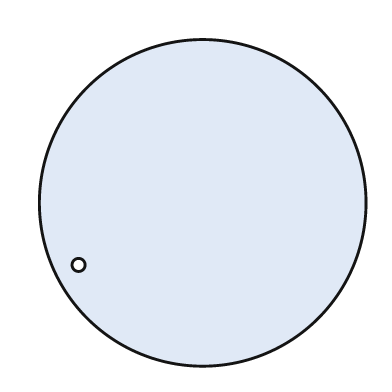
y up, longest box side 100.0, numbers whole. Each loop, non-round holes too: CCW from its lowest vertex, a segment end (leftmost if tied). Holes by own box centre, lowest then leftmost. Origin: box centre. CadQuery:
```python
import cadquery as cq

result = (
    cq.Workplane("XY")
    .moveTo(0.0, 0.0)
    .circle(50.0)
    .moveTo(-38.0, -19.0)
    .circle(2.0)
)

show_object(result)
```